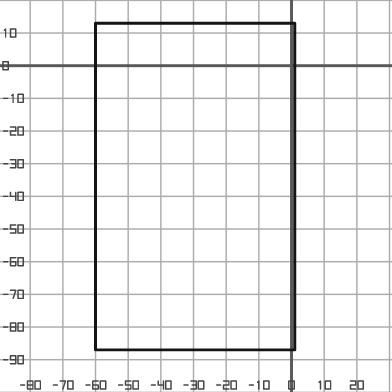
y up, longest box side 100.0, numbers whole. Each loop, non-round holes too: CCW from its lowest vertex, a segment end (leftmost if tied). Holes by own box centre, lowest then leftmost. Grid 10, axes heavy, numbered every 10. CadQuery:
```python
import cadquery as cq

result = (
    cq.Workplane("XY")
    .moveTo(-60.0, -87.0)
    .lineTo(1.0, -87.0)
    .lineTo(1.0, 13.0)
    .lineTo(-60.0, 13.0)
    .close()
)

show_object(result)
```